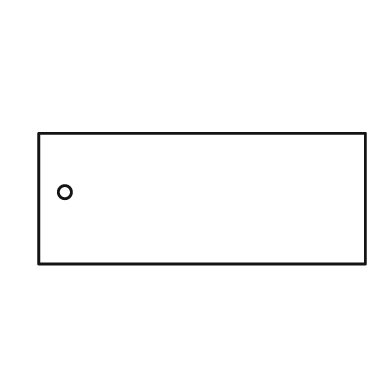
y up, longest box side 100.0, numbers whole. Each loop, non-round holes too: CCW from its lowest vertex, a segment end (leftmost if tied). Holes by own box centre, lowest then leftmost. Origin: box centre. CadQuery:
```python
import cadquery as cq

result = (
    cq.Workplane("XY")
    .moveTo(-50.0, -20.0)
    .lineTo(50.0, -20.0)
    .lineTo(50.0, 20.0)
    .lineTo(-50.0, 20.0)
    .close()
    .moveTo(-42.0, 2.0)
    .circle(2.0)
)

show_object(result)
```